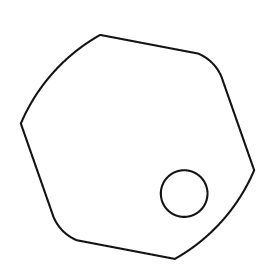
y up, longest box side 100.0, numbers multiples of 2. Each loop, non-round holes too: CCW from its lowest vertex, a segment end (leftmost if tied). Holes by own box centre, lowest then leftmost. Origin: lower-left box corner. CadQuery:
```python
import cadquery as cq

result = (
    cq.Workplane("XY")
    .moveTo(66.0, 0.0)
    .threePointArc((86.0, 16.0), (100.0, 38.0))
    .lineTo(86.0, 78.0)
    .threePointArc((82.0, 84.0), (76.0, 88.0))
    .lineTo(34.0, 96.0)
    .threePointArc((14.0, 80.0), (0.0, 58.0))
    .lineTo(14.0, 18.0)
    .threePointArc((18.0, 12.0), (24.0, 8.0))
    .close()
    .moveTo(70.0, 28.0)
    .circle(10.0)
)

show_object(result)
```